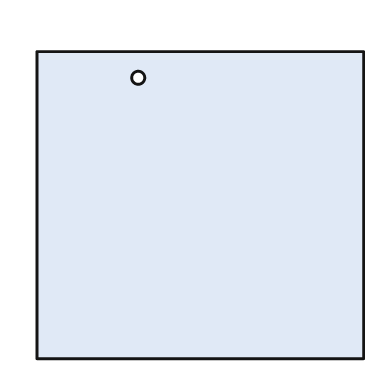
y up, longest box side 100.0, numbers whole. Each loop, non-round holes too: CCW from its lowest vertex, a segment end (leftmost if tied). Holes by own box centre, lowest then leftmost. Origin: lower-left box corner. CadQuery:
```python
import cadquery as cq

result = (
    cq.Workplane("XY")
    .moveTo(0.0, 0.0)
    .lineTo(100.0, 0.0)
    .lineTo(100.0, 94.0)
    .lineTo(0.0, 94.0)
    .close()
    .moveTo(31.0, 86.0)
    .circle(2.0)
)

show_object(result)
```